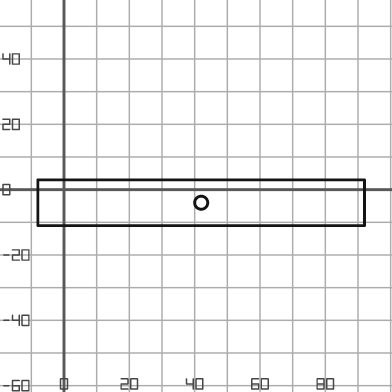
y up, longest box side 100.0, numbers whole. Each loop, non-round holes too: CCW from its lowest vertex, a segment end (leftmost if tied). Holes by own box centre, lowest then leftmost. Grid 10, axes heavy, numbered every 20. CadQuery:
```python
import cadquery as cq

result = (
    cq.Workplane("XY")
    .moveTo(-8.0, -11.0)
    .lineTo(92.0, -11.0)
    .lineTo(92.0, 3.0)
    .lineTo(-8.0, 3.0)
    .close()
    .moveTo(42.0, -4.0)
    .circle(2.0)
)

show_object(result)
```